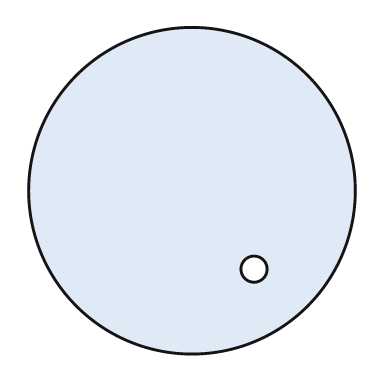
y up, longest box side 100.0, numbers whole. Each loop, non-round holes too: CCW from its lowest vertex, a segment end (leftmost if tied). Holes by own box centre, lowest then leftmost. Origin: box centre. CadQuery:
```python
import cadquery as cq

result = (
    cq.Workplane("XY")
    .moveTo(0.0, 0.0)
    .circle(50.0)
    .moveTo(19.0, -24.0)
    .circle(4.0)
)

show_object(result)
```